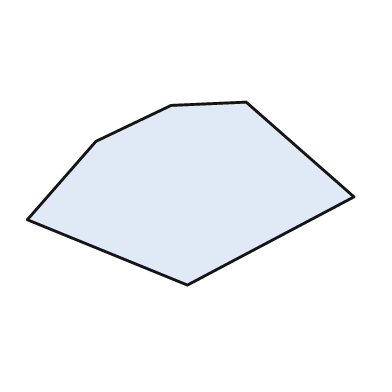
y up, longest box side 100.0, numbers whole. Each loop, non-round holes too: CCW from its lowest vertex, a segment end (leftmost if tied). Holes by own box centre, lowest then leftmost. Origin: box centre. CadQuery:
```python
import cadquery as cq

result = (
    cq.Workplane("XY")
    .moveTo(-1.0, -28.0)
    .lineTo(50.0, -1.0)
    .lineTo(17.0, 28.0)
    .lineTo(-6.0, 27.0)
    .lineTo(-29.0, 16.0)
    .lineTo(-50.0, -8.0)
    .close()
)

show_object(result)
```